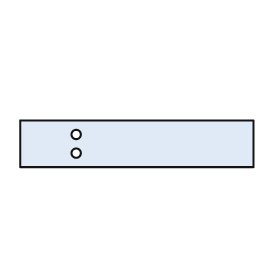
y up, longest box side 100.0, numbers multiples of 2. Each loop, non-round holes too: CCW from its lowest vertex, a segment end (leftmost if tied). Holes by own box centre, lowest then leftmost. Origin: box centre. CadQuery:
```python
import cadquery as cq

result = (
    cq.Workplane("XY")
    .moveTo(-50.0, -10.0)
    .lineTo(50.0, -10.0)
    .lineTo(50.0, 10.0)
    .lineTo(-50.0, 10.0)
    .close()
    .moveTo(-26.0, -4.0)
    .circle(2.0)
    .moveTo(-26.0, 4.0)
    .circle(2.0)
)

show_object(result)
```